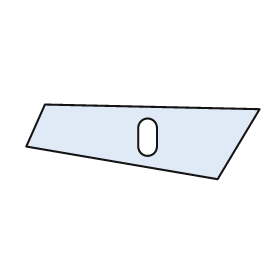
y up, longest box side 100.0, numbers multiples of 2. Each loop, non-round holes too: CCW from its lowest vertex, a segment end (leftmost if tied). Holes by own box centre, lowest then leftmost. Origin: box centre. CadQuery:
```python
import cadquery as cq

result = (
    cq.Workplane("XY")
    .moveTo(32.0, -16.0)
    .lineTo(50.0, 14.0)
    .lineTo(-42.0, 16.0)
    .lineTo(-50.0, -2.0)
    .close()
    .moveTo(-2.0, -2.0)
    .threePointArc((2.0, -6.0), (6.0, -2.0))
    .lineTo(6.0, 6.0)
    .threePointArc((2.0, 10.0), (-2.0, 6.0))
    .close()
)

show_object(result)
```